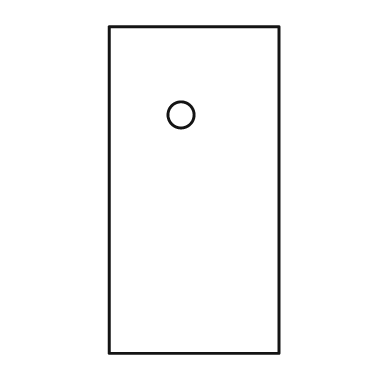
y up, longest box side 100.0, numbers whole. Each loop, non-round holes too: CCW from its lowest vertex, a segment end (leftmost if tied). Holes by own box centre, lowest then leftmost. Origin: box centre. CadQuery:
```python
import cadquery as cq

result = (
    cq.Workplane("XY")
    .moveTo(-26.0, -50.0)
    .lineTo(26.0, -50.0)
    .lineTo(26.0, 50.0)
    .lineTo(-26.0, 50.0)
    .close()
    .moveTo(-4.0, 23.0)
    .circle(4.0)
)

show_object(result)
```